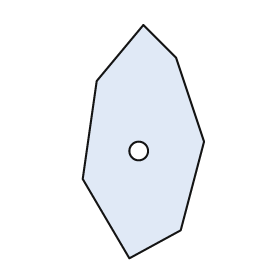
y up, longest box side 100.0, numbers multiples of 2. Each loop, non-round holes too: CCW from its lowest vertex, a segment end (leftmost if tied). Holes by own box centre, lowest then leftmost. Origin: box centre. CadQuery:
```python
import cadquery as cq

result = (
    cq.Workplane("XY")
    .moveTo(-6.0, -50.0)
    .lineTo(16.0, -38.0)
    .lineTo(26.0, 0.0)
    .lineTo(14.0, 36.0)
    .lineTo(0.0, 50.0)
    .lineTo(-20.0, 26.0)
    .lineTo(-26.0, -16.0)
    .close()
    .moveTo(-2.0, -4.0)
    .circle(4.0)
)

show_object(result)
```